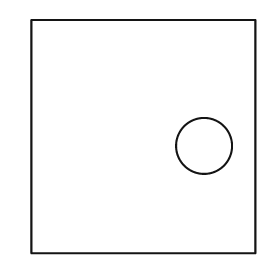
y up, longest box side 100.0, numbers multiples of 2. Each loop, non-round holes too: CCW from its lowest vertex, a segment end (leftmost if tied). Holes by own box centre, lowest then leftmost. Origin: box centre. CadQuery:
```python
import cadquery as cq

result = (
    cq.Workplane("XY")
    .moveTo(-48.0, -50.0)
    .lineTo(48.0, -50.0)
    .lineTo(48.0, 50.0)
    .lineTo(-48.0, 50.0)
    .close()
    .moveTo(26.0, -4.0)
    .circle(12.0)
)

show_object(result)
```